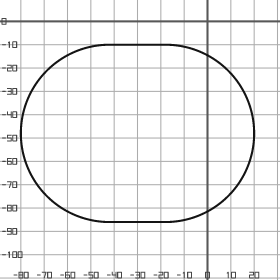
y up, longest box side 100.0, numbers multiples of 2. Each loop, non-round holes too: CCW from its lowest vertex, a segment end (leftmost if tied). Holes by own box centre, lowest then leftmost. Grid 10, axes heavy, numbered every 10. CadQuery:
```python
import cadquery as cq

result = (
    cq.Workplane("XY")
    .moveTo(-42.0, -86.0)
    .lineTo(-18.0, -86.0)
    .threePointArc((20.0, -48.0), (-18.0, -10.0))
    .lineTo(-42.0, -10.0)
    .threePointArc((-80.0, -48.0), (-42.0, -86.0))
    .close()
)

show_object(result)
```